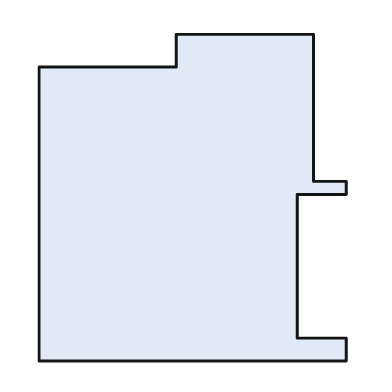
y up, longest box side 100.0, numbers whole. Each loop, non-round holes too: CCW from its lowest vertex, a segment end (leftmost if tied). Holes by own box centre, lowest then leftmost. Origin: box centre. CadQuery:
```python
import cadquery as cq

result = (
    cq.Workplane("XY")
    .moveTo(-47.0, -50.0)
    .lineTo(47.0, -50.0)
    .lineTo(47.0, -43.0)
    .lineTo(32.0, -43.0)
    .lineTo(32.0, 1.0)
    .lineTo(47.0, 1.0)
    .lineTo(47.0, 5.0)
    .lineTo(37.0, 5.0)
    .lineTo(37.0, 50.0)
    .lineTo(-5.0, 50.0)
    .lineTo(-5.0, 40.0)
    .lineTo(-47.0, 40.0)
    .close()
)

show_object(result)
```